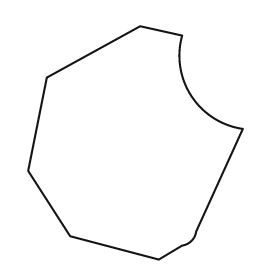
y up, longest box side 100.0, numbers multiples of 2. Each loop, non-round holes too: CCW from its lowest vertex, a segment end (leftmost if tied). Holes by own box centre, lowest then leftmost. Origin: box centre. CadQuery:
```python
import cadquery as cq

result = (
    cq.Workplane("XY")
    .moveTo(10.0, -50.0)
    .lineTo(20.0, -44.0)
    .threePointArc((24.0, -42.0), (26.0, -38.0))
    .lineTo(46.0, 6.0)
    .threePointArc((24.0, 20.0), (20.0, 46.0))
    .lineTo(2.0, 50.0)
    .lineTo(-38.0, 28.0)
    .lineTo(-46.0, -12.0)
    .lineTo(-28.0, -40.0)
    .close()
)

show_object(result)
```